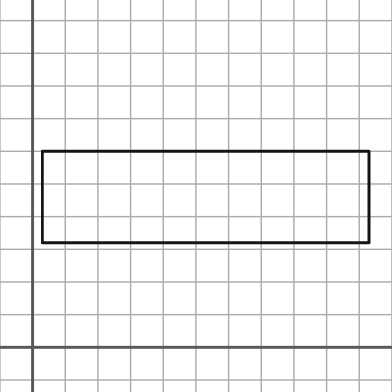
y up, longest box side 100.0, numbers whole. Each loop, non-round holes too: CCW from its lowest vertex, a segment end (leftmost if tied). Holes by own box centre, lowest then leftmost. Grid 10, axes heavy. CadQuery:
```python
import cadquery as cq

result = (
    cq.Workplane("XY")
    .moveTo(3.0, 32.0)
    .lineTo(103.0, 32.0)
    .lineTo(103.0, 60.0)
    .lineTo(3.0, 60.0)
    .close()
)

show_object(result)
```